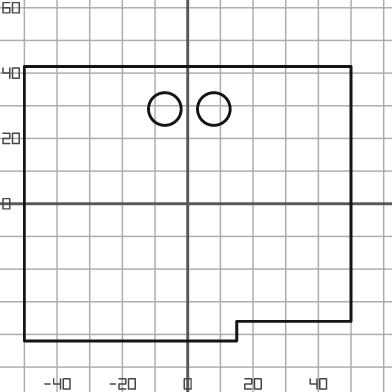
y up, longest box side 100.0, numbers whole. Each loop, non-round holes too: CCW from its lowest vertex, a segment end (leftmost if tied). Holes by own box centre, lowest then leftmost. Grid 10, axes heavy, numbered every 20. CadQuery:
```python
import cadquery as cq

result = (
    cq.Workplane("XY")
    .moveTo(-50.0, -42.0)
    .lineTo(15.0, -42.0)
    .lineTo(15.0, -36.0)
    .lineTo(50.0, -36.0)
    .lineTo(50.0, 42.0)
    .lineTo(-50.0, 42.0)
    .close()
    .moveTo(-7.0, 29.0)
    .circle(5.0)
    .moveTo(8.0, 29.0)
    .circle(5.0)
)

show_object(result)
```